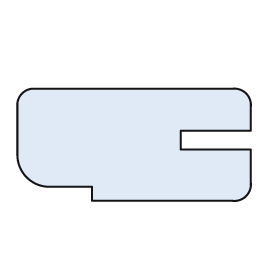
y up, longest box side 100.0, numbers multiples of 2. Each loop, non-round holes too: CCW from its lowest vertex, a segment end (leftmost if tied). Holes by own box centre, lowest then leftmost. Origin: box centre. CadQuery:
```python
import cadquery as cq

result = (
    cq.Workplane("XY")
    .moveTo(-18.0, -24.0)
    .lineTo(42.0, -24.0)
    .threePointArc((48.0, -22.0), (50.0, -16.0))
    .lineTo(50.0, -2.0)
    .lineTo(20.0, -2.0)
    .lineTo(20.0, 6.0)
    .lineTo(50.0, 6.0)
    .lineTo(50.0, 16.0)
    .threePointArc((48.0, 22.0), (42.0, 24.0))
    .lineTo(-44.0, 24.0)
    .threePointArc((-48.0, 22.0), (-50.0, 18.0))
    .lineTo(-50.0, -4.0)
    .threePointArc((-46.0, -14.0), (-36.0, -18.0))
    .lineTo(-18.0, -18.0)
    .close()
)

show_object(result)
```